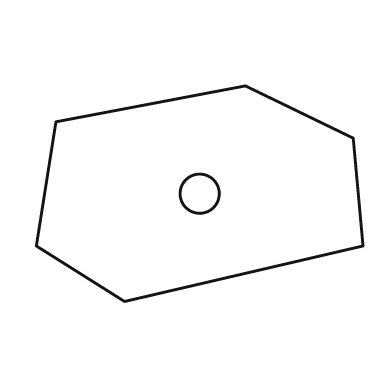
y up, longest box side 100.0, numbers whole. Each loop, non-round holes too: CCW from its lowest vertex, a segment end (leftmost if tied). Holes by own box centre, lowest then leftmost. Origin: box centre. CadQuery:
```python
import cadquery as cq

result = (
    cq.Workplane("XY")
    .moveTo(-23.0, -33.0)
    .lineTo(50.0, -16.0)
    .lineTo(47.0, 17.0)
    .lineTo(14.0, 33.0)
    .lineTo(-44.0, 22.0)
    .lineTo(-50.0, -16.0)
    .close()
    .moveTo(0.0, 0.0)
    .circle(6.0)
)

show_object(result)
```